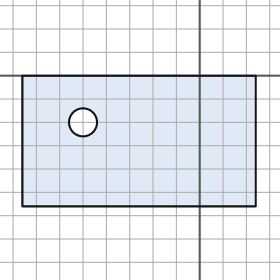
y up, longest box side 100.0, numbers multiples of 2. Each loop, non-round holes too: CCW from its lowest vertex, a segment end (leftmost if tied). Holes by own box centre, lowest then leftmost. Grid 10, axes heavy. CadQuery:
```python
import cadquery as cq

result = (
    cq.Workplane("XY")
    .moveTo(-76.0, -56.0)
    .lineTo(24.0, -56.0)
    .lineTo(24.0, 0.0)
    .lineTo(-76.0, 0.0)
    .close()
    .moveTo(-50.0, -20.0)
    .circle(6.0)
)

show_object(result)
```